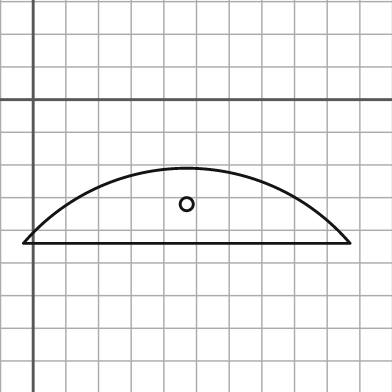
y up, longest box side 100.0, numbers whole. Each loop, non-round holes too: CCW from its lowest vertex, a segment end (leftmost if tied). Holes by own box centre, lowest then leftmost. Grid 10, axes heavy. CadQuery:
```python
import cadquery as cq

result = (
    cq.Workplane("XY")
    .moveTo(-3.0, -44.0)
    .lineTo(97.0, -44.0)
    .threePointArc((47.0, -21.0), (-3.0, -44.0))
    .close()
    .moveTo(47.0, -32.0)
    .circle(2.0)
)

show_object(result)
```